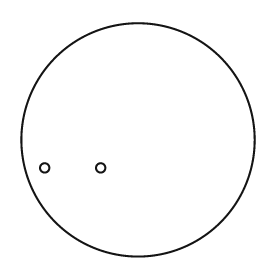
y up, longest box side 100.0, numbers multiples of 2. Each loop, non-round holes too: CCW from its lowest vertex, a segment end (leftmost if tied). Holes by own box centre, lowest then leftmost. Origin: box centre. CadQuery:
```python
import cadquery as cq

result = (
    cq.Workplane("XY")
    .moveTo(0.0, 0.0)
    .circle(50.0)
    .moveTo(-40.0, -12.0)
    .circle(2.0)
    .moveTo(-16.0, -12.0)
    .circle(2.0)
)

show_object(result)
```